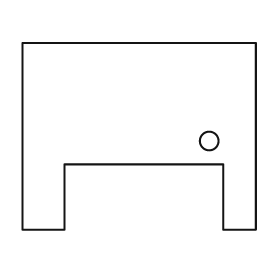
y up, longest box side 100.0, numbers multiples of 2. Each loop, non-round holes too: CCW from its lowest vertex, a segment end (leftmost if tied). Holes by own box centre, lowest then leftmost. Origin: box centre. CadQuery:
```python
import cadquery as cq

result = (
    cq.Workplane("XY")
    .moveTo(-50.0, -40.0)
    .lineTo(-32.0, -40.0)
    .lineTo(-32.0, -12.0)
    .lineTo(36.0, -12.0)
    .lineTo(36.0, -40.0)
    .lineTo(50.0, -40.0)
    .lineTo(50.0, 40.0)
    .lineTo(-50.0, 40.0)
    .close()
    .moveTo(30.0, -2.0)
    .circle(4.0)
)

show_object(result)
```